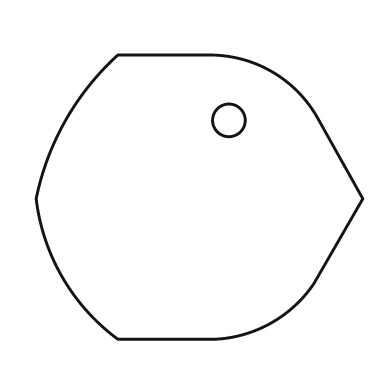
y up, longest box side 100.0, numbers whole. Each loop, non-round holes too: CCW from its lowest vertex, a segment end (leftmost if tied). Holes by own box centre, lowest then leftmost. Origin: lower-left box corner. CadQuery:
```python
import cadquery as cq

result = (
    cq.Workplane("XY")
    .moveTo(25.0, 0.0)
    .lineTo(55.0, 0.0)
    .threePointArc((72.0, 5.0), (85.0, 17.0))
    .lineTo(100.0, 43.0)
    .lineTo(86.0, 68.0)
    .threePointArc((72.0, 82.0), (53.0, 87.0))
    .lineTo(25.0, 87.0)
    .threePointArc((9.0, 67.0), (0.0, 43.0))
    .threePointArc((8.0, 19.0), (25.0, 0.0))
    .close()
    .moveTo(59.0, 67.0)
    .circle(5.0)
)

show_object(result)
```